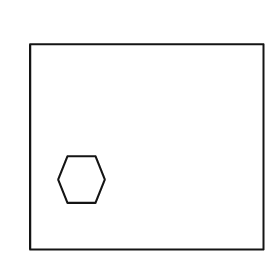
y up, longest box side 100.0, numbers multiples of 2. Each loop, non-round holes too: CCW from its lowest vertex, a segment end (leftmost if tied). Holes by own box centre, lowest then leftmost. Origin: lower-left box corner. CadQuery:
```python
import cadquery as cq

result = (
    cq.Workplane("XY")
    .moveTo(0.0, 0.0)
    .lineTo(100.0, 0.0)
    .lineTo(100.0, 88.0)
    .lineTo(0.0, 88.0)
    .close()
    .moveTo(16.0, 20.0)
    .lineTo(28.0, 20.0)
    .lineTo(32.0, 30.0)
    .lineTo(28.0, 40.0)
    .lineTo(16.0, 40.0)
    .lineTo(12.0, 30.0)
    .close()
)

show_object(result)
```